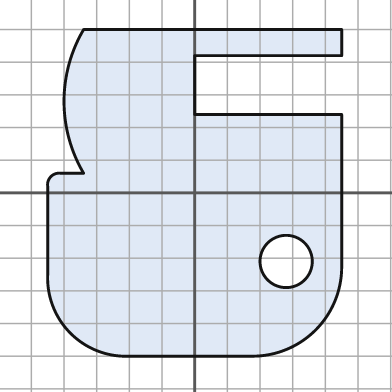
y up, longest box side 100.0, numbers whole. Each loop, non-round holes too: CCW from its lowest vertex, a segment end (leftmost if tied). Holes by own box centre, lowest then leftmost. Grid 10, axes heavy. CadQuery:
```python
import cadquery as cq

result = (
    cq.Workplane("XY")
    .moveTo(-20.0, -50.0)
    .lineTo(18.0, -50.0)
    .threePointArc((37.0, -42.0), (45.0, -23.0))
    .lineTo(45.0, 24.0)
    .lineTo(0.0, 24.0)
    .lineTo(0.0, 42.0)
    .lineTo(45.0, 42.0)
    .lineTo(45.0, 50.0)
    .lineTo(-34.0, 50.0)
    .threePointArc((-40.0, 28.0), (-34.0, 6.0))
    .lineTo(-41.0, 6.0)
    .threePointArc((-44.0, 5.0), (-45.0, 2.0))
    .lineTo(-45.0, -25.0)
    .threePointArc((-38.0, -43.0), (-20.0, -50.0))
    .close()
    .moveTo(28.0, -21.0)
    .circle(8.0)
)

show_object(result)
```